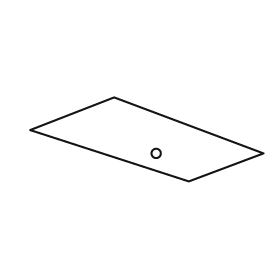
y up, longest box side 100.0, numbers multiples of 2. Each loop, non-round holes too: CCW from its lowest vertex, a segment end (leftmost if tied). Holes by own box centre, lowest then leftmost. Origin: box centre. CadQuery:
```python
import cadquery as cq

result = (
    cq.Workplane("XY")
    .moveTo(18.0, -18.0)
    .lineTo(50.0, -6.0)
    .lineTo(-14.0, 18.0)
    .lineTo(-50.0, 4.0)
    .close()
    .moveTo(4.0, -6.0)
    .circle(2.0)
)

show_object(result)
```